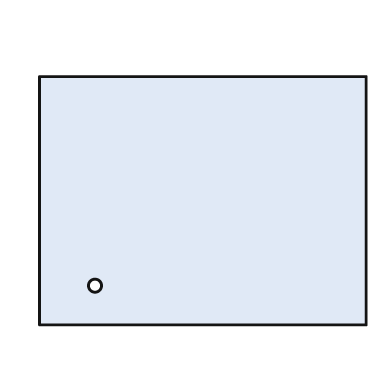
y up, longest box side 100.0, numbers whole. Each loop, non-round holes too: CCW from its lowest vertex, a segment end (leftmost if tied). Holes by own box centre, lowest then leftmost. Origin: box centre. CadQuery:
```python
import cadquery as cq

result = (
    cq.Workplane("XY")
    .moveTo(-50.0, -38.0)
    .lineTo(50.0, -38.0)
    .lineTo(50.0, 38.0)
    .lineTo(-50.0, 38.0)
    .close()
    .moveTo(-33.0, -26.0)
    .circle(2.0)
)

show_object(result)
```